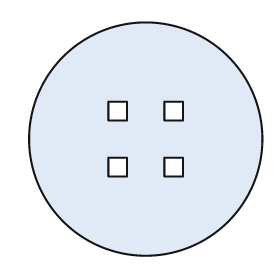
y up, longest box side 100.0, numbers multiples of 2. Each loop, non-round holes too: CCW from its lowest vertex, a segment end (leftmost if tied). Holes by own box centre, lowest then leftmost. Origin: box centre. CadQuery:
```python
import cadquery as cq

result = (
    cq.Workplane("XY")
    .moveTo(0.0, 0.0)
    .circle(50.0)
    .moveTo(-16.0, -16.0)
    .lineTo(-8.0, -16.0)
    .lineTo(-8.0, -8.0)
    .lineTo(-16.0, -8.0)
    .close()
    .moveTo(8.0, -16.0)
    .lineTo(16.0, -16.0)
    .lineTo(16.0, -8.0)
    .lineTo(8.0, -8.0)
    .close()
    .moveTo(-16.0, 8.0)
    .lineTo(-8.0, 8.0)
    .lineTo(-8.0, 16.0)
    .lineTo(-16.0, 16.0)
    .close()
    .moveTo(8.0, 8.0)
    .lineTo(16.0, 8.0)
    .lineTo(16.0, 16.0)
    .lineTo(8.0, 16.0)
    .close()
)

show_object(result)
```